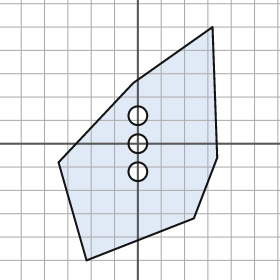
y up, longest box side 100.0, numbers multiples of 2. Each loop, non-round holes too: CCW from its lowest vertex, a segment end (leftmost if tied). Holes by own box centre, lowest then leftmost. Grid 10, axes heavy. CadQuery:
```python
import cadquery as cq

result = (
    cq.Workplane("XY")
    .moveTo(-22.0, -50.0)
    .lineTo(24.0, -32.0)
    .lineTo(34.0, -6.0)
    .lineTo(32.0, 50.0)
    .lineTo(-2.0, 26.0)
    .lineTo(-34.0, -8.0)
    .close()
    .moveTo(0.0, -12.0)
    .circle(4.0)
    .moveTo(0.0, 0.0)
    .circle(4.0)
    .moveTo(0.0, 12.0)
    .circle(4.0)
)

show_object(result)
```